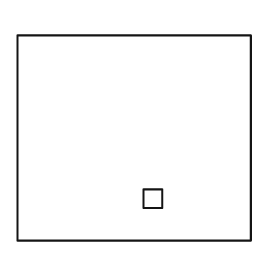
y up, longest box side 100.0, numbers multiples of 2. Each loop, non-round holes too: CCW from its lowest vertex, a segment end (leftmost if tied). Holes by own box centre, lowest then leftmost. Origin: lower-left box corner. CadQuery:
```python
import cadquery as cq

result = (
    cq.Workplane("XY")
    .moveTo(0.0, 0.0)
    .lineTo(100.0, 0.0)
    .lineTo(100.0, 88.0)
    .lineTo(0.0, 88.0)
    .close()
    .moveTo(54.0, 14.0)
    .lineTo(62.0, 14.0)
    .lineTo(62.0, 22.0)
    .lineTo(54.0, 22.0)
    .close()
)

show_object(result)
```